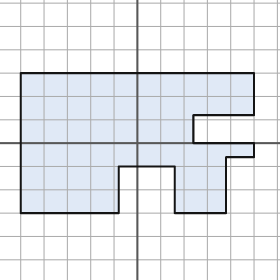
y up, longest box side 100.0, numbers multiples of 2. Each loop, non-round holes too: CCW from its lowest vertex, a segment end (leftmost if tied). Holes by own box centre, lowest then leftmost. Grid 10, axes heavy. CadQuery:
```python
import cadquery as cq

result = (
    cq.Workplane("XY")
    .moveTo(-50.0, -30.0)
    .lineTo(-8.0, -30.0)
    .lineTo(-8.0, -10.0)
    .lineTo(16.0, -10.0)
    .lineTo(16.0, -30.0)
    .lineTo(38.0, -30.0)
    .lineTo(38.0, -6.0)
    .lineTo(50.0, -6.0)
    .lineTo(50.0, 0.0)
    .lineTo(24.0, 0.0)
    .lineTo(24.0, 12.0)
    .lineTo(50.0, 12.0)
    .lineTo(50.0, 30.0)
    .lineTo(-50.0, 30.0)
    .close()
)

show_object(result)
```